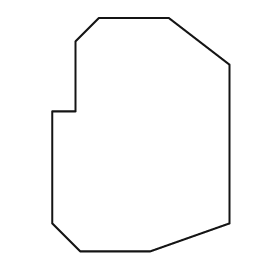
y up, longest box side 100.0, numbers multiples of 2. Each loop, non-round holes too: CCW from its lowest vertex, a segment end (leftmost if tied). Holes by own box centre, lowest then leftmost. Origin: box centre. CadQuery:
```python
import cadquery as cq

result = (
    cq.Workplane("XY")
    .moveTo(-26.0, -50.0)
    .lineTo(4.0, -50.0)
    .lineTo(38.0, -38.0)
    .lineTo(38.0, 30.0)
    .lineTo(12.0, 50.0)
    .lineTo(-18.0, 50.0)
    .lineTo(-28.0, 40.0)
    .lineTo(-28.0, 10.0)
    .lineTo(-38.0, 10.0)
    .lineTo(-38.0, -38.0)
    .close()
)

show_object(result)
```